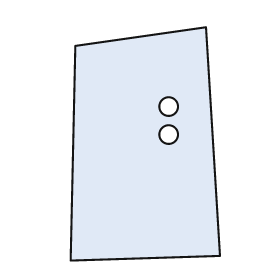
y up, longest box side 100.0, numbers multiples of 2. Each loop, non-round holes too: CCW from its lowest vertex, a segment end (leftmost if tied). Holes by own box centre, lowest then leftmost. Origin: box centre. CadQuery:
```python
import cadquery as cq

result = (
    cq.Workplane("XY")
    .moveTo(-32.0, -50.0)
    .lineTo(32.0, -48.0)
    .lineTo(26.0, 50.0)
    .lineTo(-30.0, 42.0)
    .close()
    .moveTo(10.0, 4.0)
    .circle(4.0)
    .moveTo(10.0, 16.0)
    .circle(4.0)
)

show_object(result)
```